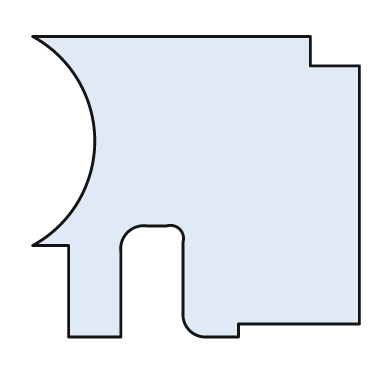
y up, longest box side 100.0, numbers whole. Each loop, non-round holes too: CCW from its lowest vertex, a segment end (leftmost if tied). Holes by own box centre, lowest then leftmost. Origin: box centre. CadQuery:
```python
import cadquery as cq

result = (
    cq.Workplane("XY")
    .moveTo(-39.0, -46.0)
    .lineTo(-23.0, -46.0)
    .lineTo(-23.0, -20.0)
    .threePointArc((-21.0, -14.0), (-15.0, -12.0))
    .lineTo(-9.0, -12.0)
    .threePointArc((-5.0, -13.0), (-4.0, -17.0))
    .lineTo(-4.0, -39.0)
    .threePointArc((-2.0, -44.0), (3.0, -46.0))
    .lineTo(13.0, -46.0)
    .lineTo(13.0, -42.0)
    .lineTo(50.0, -42.0)
    .lineTo(50.0, 37.0)
    .lineTo(35.0, 37.0)
    .lineTo(35.0, 46.0)
    .lineTo(-50.0, 46.0)
    .threePointArc((-31.0, 14.0), (-50.0, -18.0))
    .lineTo(-39.0, -18.0)
    .close()
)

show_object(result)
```